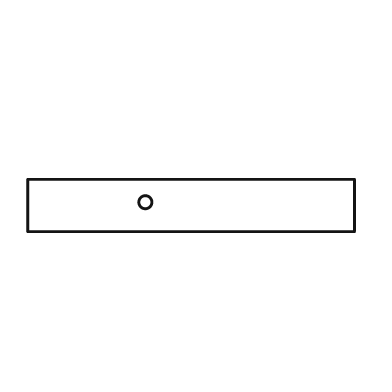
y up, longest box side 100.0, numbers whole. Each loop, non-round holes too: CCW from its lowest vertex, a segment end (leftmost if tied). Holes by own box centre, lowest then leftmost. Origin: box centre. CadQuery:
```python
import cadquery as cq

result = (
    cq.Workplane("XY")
    .moveTo(-50.0, -8.0)
    .lineTo(50.0, -8.0)
    .lineTo(50.0, 8.0)
    .lineTo(-50.0, 8.0)
    .close()
    .moveTo(-14.0, 1.0)
    .circle(2.0)
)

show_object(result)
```